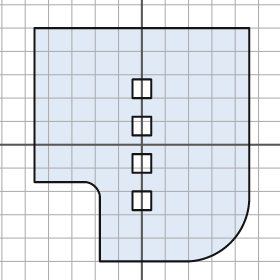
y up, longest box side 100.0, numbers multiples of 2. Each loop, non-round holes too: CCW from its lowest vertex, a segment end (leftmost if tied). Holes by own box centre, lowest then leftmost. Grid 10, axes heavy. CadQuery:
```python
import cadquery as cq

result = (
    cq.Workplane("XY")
    .moveTo(-18.0, -50.0)
    .lineTo(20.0, -50.0)
    .threePointArc((38.0, -42.0), (46.0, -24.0))
    .lineTo(46.0, 50.0)
    .lineTo(-46.0, 50.0)
    .lineTo(-46.0, -16.0)
    .lineTo(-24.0, -16.0)
    .threePointArc((-20.0, -18.0), (-18.0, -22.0))
    .close()
    .moveTo(-4.0, -28.0)
    .lineTo(4.0, -28.0)
    .lineTo(4.0, -20.0)
    .lineTo(-4.0, -20.0)
    .close()
    .moveTo(-4.0, -12.0)
    .lineTo(4.0, -12.0)
    .lineTo(4.0, -4.0)
    .lineTo(-4.0, -4.0)
    .close()
    .moveTo(-4.0, 4.0)
    .lineTo(4.0, 4.0)
    .lineTo(4.0, 12.0)
    .lineTo(-4.0, 12.0)
    .close()
    .moveTo(-4.0, 20.0)
    .lineTo(4.0, 20.0)
    .lineTo(4.0, 28.0)
    .lineTo(-4.0, 28.0)
    .close()
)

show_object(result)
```